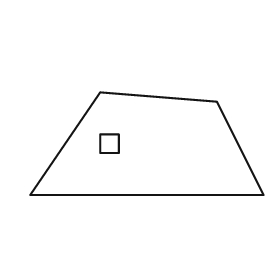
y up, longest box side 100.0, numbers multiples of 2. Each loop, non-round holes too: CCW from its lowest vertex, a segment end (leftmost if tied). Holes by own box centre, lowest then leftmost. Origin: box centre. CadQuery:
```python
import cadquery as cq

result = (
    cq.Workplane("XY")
    .moveTo(-50.0, -22.0)
    .lineTo(50.0, -22.0)
    .lineTo(30.0, 18.0)
    .lineTo(-20.0, 22.0)
    .close()
    .moveTo(-20.0, -4.0)
    .lineTo(-12.0, -4.0)
    .lineTo(-12.0, 4.0)
    .lineTo(-20.0, 4.0)
    .close()
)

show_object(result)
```